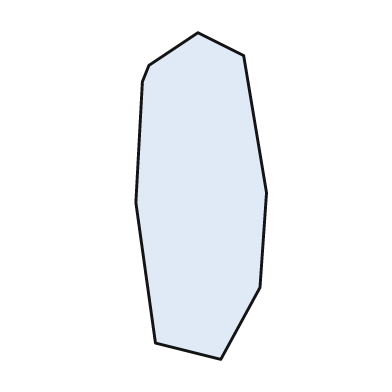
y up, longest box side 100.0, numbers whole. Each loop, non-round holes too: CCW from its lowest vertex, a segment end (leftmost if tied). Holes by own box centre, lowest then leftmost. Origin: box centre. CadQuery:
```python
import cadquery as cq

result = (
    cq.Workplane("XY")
    .moveTo(6.0, -50.0)
    .lineTo(18.0, -28.0)
    .lineTo(20.0, 1.0)
    .lineTo(13.0, 43.0)
    .lineTo(-1.0, 50.0)
    .lineTo(-16.0, 40.0)
    .lineTo(-18.0, 35.0)
    .lineTo(-20.0, -2.0)
    .lineTo(-14.0, -45.0)
    .close()
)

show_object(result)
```